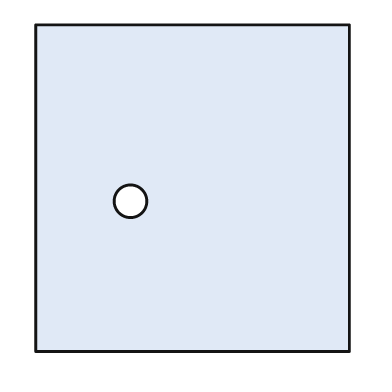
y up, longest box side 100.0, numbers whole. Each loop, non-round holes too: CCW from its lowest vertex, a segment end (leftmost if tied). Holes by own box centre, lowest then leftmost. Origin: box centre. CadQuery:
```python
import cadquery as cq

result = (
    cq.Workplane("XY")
    .moveTo(-48.0, -50.0)
    .lineTo(48.0, -50.0)
    .lineTo(48.0, 50.0)
    .lineTo(-48.0, 50.0)
    .close()
    .moveTo(-19.0, -4.0)
    .circle(5.0)
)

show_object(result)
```